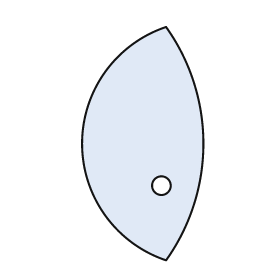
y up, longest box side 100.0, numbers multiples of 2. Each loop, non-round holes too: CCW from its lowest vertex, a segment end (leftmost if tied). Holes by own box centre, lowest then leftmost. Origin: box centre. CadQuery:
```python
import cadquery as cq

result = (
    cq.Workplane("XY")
    .moveTo(10.0, -50.0)
    .threePointArc((26.0, 0.0), (10.0, 50.0))
    .threePointArc((-26.0, 0.0), (10.0, -50.0))
    .close()
    .moveTo(8.0, -18.0)
    .circle(4.0)
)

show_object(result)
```